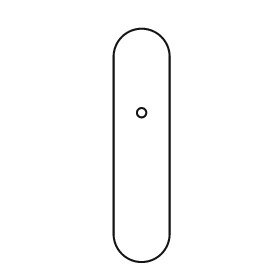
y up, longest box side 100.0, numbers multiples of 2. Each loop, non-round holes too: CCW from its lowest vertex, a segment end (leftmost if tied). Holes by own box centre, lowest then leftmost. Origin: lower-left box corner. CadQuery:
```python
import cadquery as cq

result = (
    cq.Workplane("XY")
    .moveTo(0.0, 12.0)
    .threePointArc((12.0, 0.0), (24.0, 12.0))
    .lineTo(24.0, 88.0)
    .threePointArc((12.0, 100.0), (0.0, 88.0))
    .close()
    .moveTo(12.0, 64.0)
    .circle(2.0)
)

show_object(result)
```